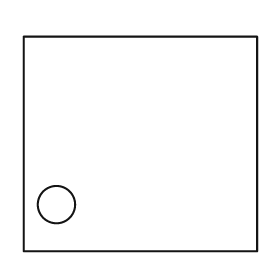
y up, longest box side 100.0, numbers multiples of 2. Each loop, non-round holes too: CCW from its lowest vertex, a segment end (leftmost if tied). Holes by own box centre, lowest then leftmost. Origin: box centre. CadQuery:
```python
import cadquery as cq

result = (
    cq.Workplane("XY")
    .moveTo(-50.0, -46.0)
    .lineTo(50.0, -46.0)
    .lineTo(50.0, 46.0)
    .lineTo(-50.0, 46.0)
    .close()
    .moveTo(-36.0, -26.0)
    .circle(8.0)
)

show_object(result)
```